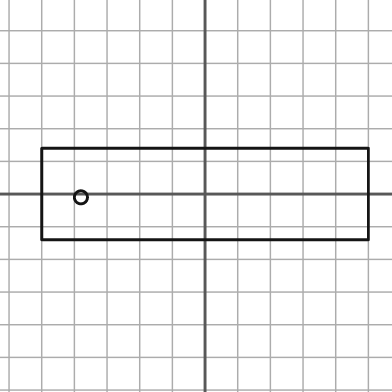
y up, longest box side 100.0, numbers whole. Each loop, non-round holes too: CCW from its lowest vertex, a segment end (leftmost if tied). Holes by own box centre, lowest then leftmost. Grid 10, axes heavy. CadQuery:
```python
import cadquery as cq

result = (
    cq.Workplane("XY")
    .moveTo(-50.0, -14.0)
    .lineTo(50.0, -14.0)
    .lineTo(50.0, 14.0)
    .lineTo(-50.0, 14.0)
    .close()
    .moveTo(-38.0, -1.0)
    .circle(2.0)
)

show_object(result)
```